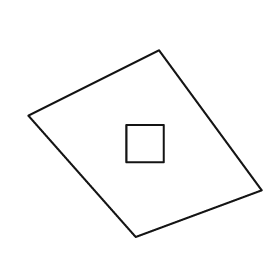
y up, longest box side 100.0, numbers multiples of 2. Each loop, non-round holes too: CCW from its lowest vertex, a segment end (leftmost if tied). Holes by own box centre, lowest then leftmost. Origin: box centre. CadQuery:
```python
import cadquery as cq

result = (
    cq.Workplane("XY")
    .moveTo(-4.0, -40.0)
    .lineTo(50.0, -20.0)
    .lineTo(6.0, 40.0)
    .lineTo(-50.0, 12.0)
    .close()
    .moveTo(-8.0, -8.0)
    .lineTo(8.0, -8.0)
    .lineTo(8.0, 8.0)
    .lineTo(-8.0, 8.0)
    .close()
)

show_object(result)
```